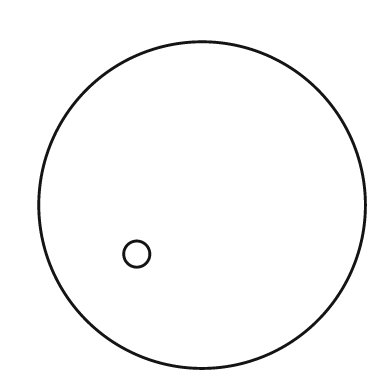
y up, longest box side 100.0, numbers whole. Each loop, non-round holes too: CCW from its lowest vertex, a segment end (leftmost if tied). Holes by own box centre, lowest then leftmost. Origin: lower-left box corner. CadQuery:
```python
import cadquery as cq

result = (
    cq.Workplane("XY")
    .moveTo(50.0, 50.0)
    .circle(50.0)
    .moveTo(30.0, 35.0)
    .circle(4.0)
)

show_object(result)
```